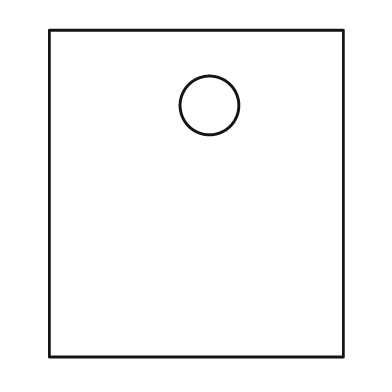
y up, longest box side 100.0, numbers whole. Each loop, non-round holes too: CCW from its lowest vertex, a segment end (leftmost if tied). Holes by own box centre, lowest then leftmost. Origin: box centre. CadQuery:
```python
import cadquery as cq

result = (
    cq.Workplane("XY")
    .moveTo(-45.0, -50.0)
    .lineTo(45.0, -50.0)
    .lineTo(45.0, 50.0)
    .lineTo(-45.0, 50.0)
    .close()
    .moveTo(4.0, 27.0)
    .circle(9.0)
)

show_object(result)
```